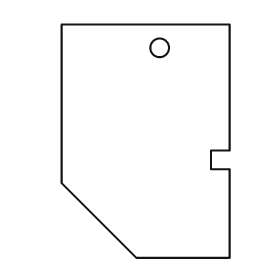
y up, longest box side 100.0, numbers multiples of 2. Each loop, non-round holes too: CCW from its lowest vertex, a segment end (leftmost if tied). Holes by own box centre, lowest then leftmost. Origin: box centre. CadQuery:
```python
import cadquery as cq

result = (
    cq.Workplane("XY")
    .moveTo(-4.0, -50.0)
    .lineTo(36.0, -50.0)
    .lineTo(36.0, -12.0)
    .lineTo(28.0, -12.0)
    .lineTo(28.0, -4.0)
    .lineTo(36.0, -4.0)
    .lineTo(36.0, 50.0)
    .lineTo(-36.0, 50.0)
    .lineTo(-36.0, -18.0)
    .close()
    .moveTo(6.0, 40.0)
    .circle(4.0)
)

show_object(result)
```